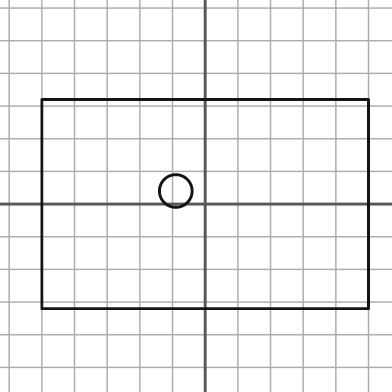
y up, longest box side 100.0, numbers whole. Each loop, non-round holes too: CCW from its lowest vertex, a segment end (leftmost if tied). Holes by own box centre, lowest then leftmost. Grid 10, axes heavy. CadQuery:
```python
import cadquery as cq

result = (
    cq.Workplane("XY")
    .moveTo(-50.0, -32.0)
    .lineTo(50.0, -32.0)
    .lineTo(50.0, 32.0)
    .lineTo(-50.0, 32.0)
    .close()
    .moveTo(-9.0, 4.0)
    .circle(5.0)
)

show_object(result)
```